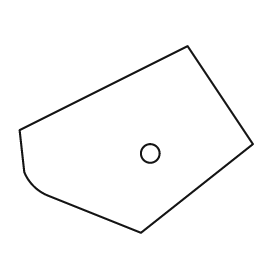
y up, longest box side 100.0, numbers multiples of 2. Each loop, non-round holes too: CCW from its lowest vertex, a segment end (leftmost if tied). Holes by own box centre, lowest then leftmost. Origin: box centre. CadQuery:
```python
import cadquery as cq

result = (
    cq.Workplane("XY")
    .moveTo(2.0, -40.0)
    .lineTo(50.0, -2.0)
    .lineTo(22.0, 40.0)
    .lineTo(-50.0, 4.0)
    .lineTo(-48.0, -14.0)
    .threePointArc((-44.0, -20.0), (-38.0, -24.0))
    .close()
    .moveTo(6.0, -6.0)
    .circle(4.0)
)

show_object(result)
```